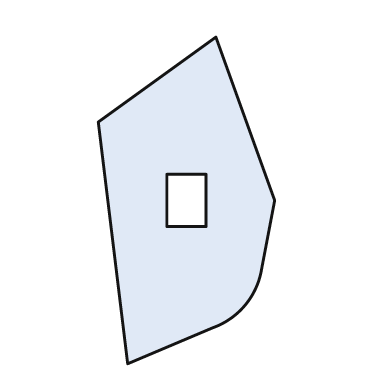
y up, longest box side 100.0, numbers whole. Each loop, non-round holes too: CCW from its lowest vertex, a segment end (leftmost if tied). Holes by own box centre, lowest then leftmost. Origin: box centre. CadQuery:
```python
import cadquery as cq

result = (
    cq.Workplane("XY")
    .moveTo(-18.0, -50.0)
    .lineTo(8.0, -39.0)
    .threePointArc((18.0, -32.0), (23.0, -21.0))
    .lineTo(27.0, 0.0)
    .lineTo(9.0, 50.0)
    .lineTo(-27.0, 24.0)
    .close()
    .moveTo(-6.0, -8.0)
    .lineTo(6.0, -8.0)
    .lineTo(6.0, 8.0)
    .lineTo(-6.0, 8.0)
    .close()
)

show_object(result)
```